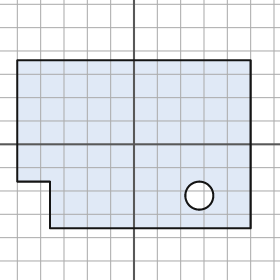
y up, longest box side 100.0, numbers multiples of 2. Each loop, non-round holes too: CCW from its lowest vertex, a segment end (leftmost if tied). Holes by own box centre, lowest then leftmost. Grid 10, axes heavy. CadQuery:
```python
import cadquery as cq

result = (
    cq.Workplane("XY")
    .moveTo(-36.0, -36.0)
    .lineTo(50.0, -36.0)
    .lineTo(50.0, 36.0)
    .lineTo(-50.0, 36.0)
    .lineTo(-50.0, -16.0)
    .lineTo(-36.0, -16.0)
    .close()
    .moveTo(28.0, -22.0)
    .circle(6.0)
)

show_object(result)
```